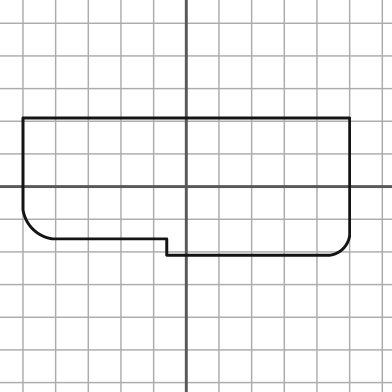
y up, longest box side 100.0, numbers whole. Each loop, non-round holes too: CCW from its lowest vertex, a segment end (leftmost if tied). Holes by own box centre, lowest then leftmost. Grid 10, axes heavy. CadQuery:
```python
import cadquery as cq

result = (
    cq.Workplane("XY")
    .moveTo(-6.0, -21.0)
    .lineTo(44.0, -21.0)
    .threePointArc((48.0, -19.0), (50.0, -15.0))
    .lineTo(50.0, 21.0)
    .lineTo(-50.0, 21.0)
    .lineTo(-50.0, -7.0)
    .threePointArc((-47.0, -13.0), (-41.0, -16.0))
    .lineTo(-6.0, -16.0)
    .close()
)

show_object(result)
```